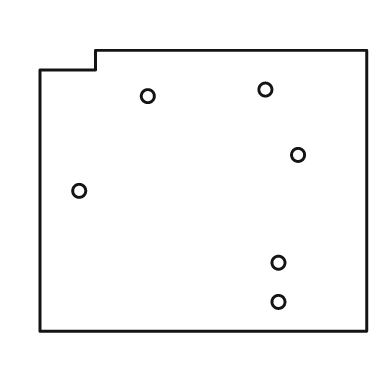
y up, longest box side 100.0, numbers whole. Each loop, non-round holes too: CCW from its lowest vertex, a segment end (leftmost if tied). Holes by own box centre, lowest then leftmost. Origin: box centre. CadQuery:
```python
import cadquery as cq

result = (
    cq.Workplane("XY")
    .moveTo(-50.0, -43.0)
    .lineTo(50.0, -43.0)
    .lineTo(50.0, 43.0)
    .lineTo(-33.0, 43.0)
    .lineTo(-33.0, 37.0)
    .lineTo(-50.0, 37.0)
    .close()
    .moveTo(23.0, -34.0)
    .circle(2.0)
    .moveTo(23.0, -22.0)
    .circle(2.0)
    .moveTo(-38.0, 0.0)
    .circle(2.0)
    .moveTo(29.0, 11.0)
    .circle(2.0)
    .moveTo(-17.0, 29.0)
    .circle(2.0)
    .moveTo(19.0, 31.0)
    .circle(2.0)
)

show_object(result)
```